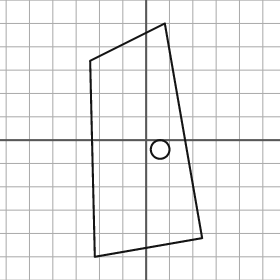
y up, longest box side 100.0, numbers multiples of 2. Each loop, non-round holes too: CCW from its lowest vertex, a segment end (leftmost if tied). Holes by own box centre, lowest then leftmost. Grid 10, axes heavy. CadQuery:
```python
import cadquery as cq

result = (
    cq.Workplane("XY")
    .moveTo(-22.0, -50.0)
    .lineTo(24.0, -42.0)
    .lineTo(8.0, 50.0)
    .lineTo(-24.0, 34.0)
    .close()
    .moveTo(6.0, -4.0)
    .circle(4.0)
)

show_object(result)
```